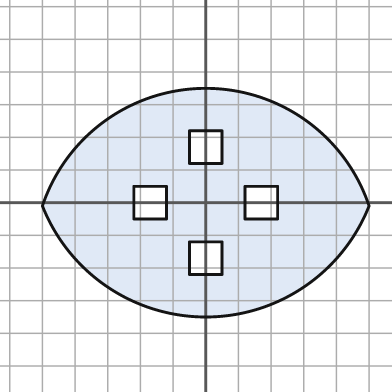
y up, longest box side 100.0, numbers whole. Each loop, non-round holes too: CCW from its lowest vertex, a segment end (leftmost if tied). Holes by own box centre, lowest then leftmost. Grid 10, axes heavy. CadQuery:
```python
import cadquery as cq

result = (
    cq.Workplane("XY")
    .moveTo(-50.0, -1.0)
    .threePointArc((0.0, -35.0), (50.0, -1.0))
    .threePointArc((0.0, 35.0), (-50.0, -1.0))
    .close()
    .moveTo(-5.0, -22.0)
    .lineTo(5.0, -22.0)
    .lineTo(5.0, -12.0)
    .lineTo(-5.0, -12.0)
    .close()
    .moveTo(-22.0, -5.0)
    .lineTo(-12.0, -5.0)
    .lineTo(-12.0, 5.0)
    .lineTo(-22.0, 5.0)
    .close()
    .moveTo(12.0, -5.0)
    .lineTo(22.0, -5.0)
    .lineTo(22.0, 5.0)
    .lineTo(12.0, 5.0)
    .close()
    .moveTo(-5.0, 12.0)
    .lineTo(5.0, 12.0)
    .lineTo(5.0, 22.0)
    .lineTo(-5.0, 22.0)
    .close()
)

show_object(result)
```